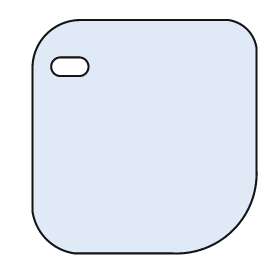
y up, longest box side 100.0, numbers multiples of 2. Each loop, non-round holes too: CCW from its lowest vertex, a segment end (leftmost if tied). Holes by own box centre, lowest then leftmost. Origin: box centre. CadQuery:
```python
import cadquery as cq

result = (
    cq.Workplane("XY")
    .moveTo(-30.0, -50.0)
    .lineTo(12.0, -50.0)
    .threePointArc((38.0, -40.0), (48.0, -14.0))
    .lineTo(48.0, 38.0)
    .threePointArc((44.0, 46.0), (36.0, 50.0))
    .lineTo(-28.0, 50.0)
    .threePointArc((-42.0, 44.0), (-48.0, 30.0))
    .lineTo(-48.0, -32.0)
    .threePointArc((-42.0, -44.0), (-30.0, -50.0))
    .close()
    .moveTo(-36.0, 26.0)
    .lineTo(-28.0, 26.0)
    .threePointArc((-24.0, 30.0), (-28.0, 34.0))
    .lineTo(-36.0, 34.0)
    .threePointArc((-40.0, 30.0), (-36.0, 26.0))
    .close()
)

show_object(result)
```